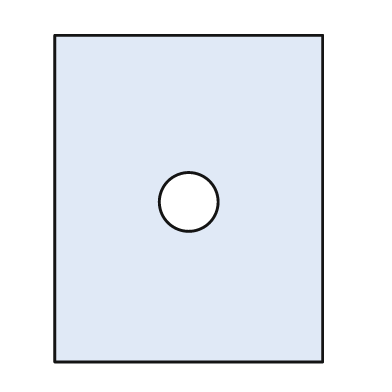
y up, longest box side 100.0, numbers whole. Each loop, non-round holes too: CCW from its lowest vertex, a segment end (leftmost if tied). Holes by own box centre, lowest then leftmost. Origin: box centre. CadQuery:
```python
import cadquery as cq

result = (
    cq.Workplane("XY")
    .moveTo(-41.0, -50.0)
    .lineTo(41.0, -50.0)
    .lineTo(41.0, 50.0)
    .lineTo(-41.0, 50.0)
    .close()
    .moveTo(0.0, -1.0)
    .circle(9.0)
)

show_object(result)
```